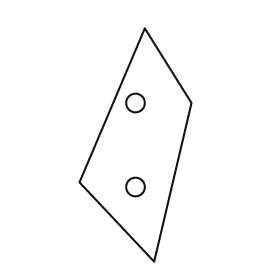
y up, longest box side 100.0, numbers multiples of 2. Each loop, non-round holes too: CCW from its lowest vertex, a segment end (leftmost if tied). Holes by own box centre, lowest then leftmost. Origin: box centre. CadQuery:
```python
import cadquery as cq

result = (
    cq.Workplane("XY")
    .moveTo(8.0, -50.0)
    .lineTo(24.0, 18.0)
    .lineTo(4.0, 50.0)
    .lineTo(-24.0, -16.0)
    .close()
    .moveTo(0.0, -18.0)
    .circle(4.0)
    .moveTo(0.0, 18.0)
    .circle(4.0)
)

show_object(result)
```